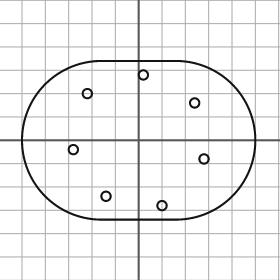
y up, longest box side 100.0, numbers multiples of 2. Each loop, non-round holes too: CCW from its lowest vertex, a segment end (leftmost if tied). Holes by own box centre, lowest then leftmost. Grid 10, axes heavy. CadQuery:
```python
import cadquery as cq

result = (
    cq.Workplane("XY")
    .moveTo(-16.0, -34.0)
    .lineTo(16.0, -34.0)
    .threePointArc((50.0, 0.0), (16.0, 34.0))
    .lineTo(-16.0, 34.0)
    .threePointArc((-50.0, 0.0), (-16.0, -34.0))
    .close()
    .moveTo(10.0, -28.0)
    .circle(2.0)
    .moveTo(-14.0, -24.0)
    .circle(2.0)
    .moveTo(28.0, -8.0)
    .circle(2.0)
    .moveTo(-28.0, -4.0)
    .circle(2.0)
    .moveTo(24.0, 16.0)
    .circle(2.0)
    .moveTo(-22.0, 20.0)
    .circle(2.0)
    .moveTo(2.0, 28.0)
    .circle(2.0)
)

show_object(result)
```